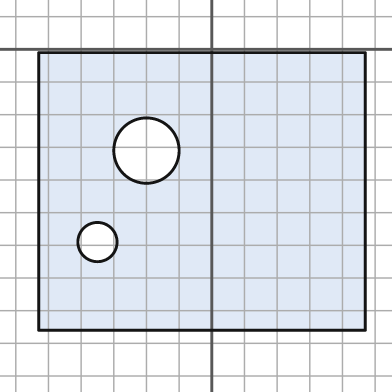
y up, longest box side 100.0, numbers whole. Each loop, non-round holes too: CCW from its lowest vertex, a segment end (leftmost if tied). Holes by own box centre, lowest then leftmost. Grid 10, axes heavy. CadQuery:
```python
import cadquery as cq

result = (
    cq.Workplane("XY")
    .moveTo(-53.0, -86.0)
    .lineTo(47.0, -86.0)
    .lineTo(47.0, -1.0)
    .lineTo(-53.0, -1.0)
    .close()
    .moveTo(-35.0, -59.0)
    .circle(6.0)
    .moveTo(-20.0, -31.0)
    .circle(10.0)
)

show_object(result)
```